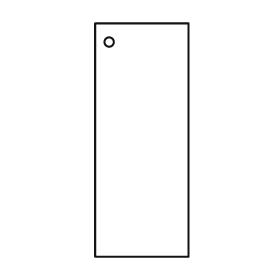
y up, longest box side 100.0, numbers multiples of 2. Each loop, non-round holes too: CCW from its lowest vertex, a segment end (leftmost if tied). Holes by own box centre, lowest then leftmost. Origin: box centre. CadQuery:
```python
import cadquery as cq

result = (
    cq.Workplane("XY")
    .moveTo(-20.0, -50.0)
    .lineTo(20.0, -50.0)
    .lineTo(20.0, 50.0)
    .lineTo(-20.0, 50.0)
    .close()
    .moveTo(-14.0, 42.0)
    .circle(2.0)
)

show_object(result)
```